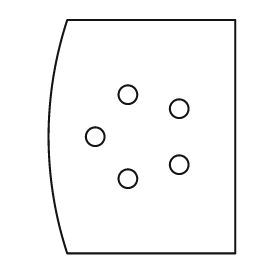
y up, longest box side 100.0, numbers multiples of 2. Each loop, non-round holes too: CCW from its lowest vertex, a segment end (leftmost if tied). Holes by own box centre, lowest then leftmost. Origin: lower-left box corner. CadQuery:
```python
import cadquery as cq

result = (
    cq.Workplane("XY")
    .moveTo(8.0, 0.0)
    .lineTo(80.0, 0.0)
    .lineTo(80.0, 100.0)
    .lineTo(8.0, 100.0)
    .threePointArc((0.0, 50.0), (8.0, 0.0))
    .close()
    .moveTo(34.0, 32.0)
    .circle(4.0)
    .moveTo(56.0, 38.0)
    .circle(4.0)
    .moveTo(20.0, 50.0)
    .circle(4.0)
    .moveTo(56.0, 62.0)
    .circle(4.0)
    .moveTo(34.0, 68.0)
    .circle(4.0)
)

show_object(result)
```